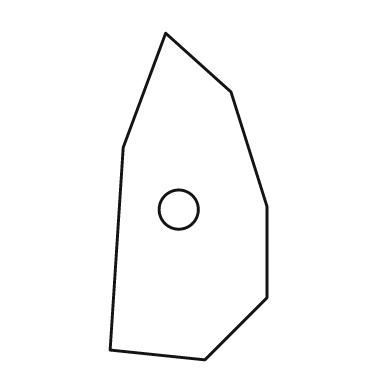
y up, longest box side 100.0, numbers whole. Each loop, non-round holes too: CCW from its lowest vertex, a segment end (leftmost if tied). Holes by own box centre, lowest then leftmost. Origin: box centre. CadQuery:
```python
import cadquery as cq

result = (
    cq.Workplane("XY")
    .moveTo(5.0, -50.0)
    .lineTo(24.0, -31.0)
    .lineTo(24.0, -3.0)
    .lineTo(13.0, 32.0)
    .lineTo(-7.0, 50.0)
    .lineTo(-20.0, 15.0)
    .lineTo(-24.0, -47.0)
    .close()
    .moveTo(-3.0, -4.0)
    .circle(6.0)
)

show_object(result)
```